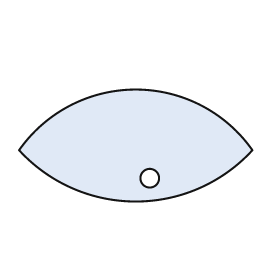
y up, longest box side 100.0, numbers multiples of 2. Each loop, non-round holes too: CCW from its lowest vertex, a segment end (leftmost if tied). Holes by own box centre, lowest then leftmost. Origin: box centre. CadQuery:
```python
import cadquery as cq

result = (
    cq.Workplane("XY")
    .moveTo(-50.0, -2.0)
    .threePointArc((0.0, -24.0), (50.0, -2.0))
    .threePointArc((0.0, 24.0), (-50.0, -2.0))
    .close()
    .moveTo(6.0, -14.0)
    .circle(4.0)
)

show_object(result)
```